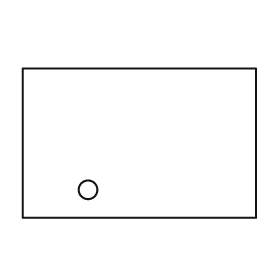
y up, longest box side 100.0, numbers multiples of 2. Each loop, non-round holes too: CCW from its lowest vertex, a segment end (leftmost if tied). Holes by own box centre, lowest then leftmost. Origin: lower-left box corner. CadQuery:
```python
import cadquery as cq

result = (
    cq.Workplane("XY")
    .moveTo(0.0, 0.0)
    .lineTo(100.0, 0.0)
    .lineTo(100.0, 64.0)
    .lineTo(0.0, 64.0)
    .close()
    .moveTo(28.0, 12.0)
    .circle(4.0)
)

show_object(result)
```